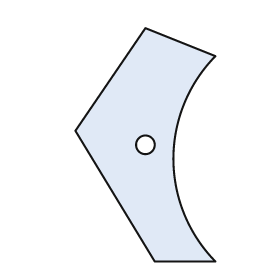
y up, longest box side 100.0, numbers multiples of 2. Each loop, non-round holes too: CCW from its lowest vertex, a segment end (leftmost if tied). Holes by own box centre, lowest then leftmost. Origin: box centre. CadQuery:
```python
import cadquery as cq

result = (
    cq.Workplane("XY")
    .moveTo(4.0, -50.0)
    .lineTo(30.0, -50.0)
    .threePointArc((12.0, -6.0), (30.0, 38.0))
    .lineTo(0.0, 50.0)
    .lineTo(-30.0, 6.0)
    .close()
    .moveTo(0.0, 0.0)
    .circle(4.0)
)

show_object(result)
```